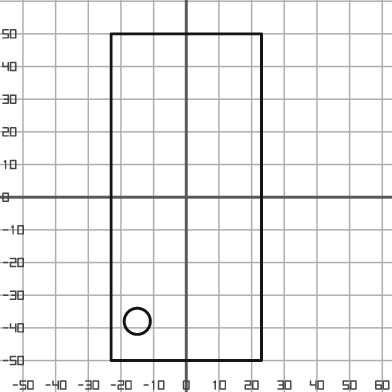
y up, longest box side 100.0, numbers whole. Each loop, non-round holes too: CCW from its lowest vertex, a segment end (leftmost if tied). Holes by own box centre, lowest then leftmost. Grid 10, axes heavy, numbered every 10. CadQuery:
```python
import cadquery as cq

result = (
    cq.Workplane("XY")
    .moveTo(-23.0, -50.0)
    .lineTo(23.0, -50.0)
    .lineTo(23.0, 50.0)
    .lineTo(-23.0, 50.0)
    .close()
    .moveTo(-15.0, -38.0)
    .circle(4.0)
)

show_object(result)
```